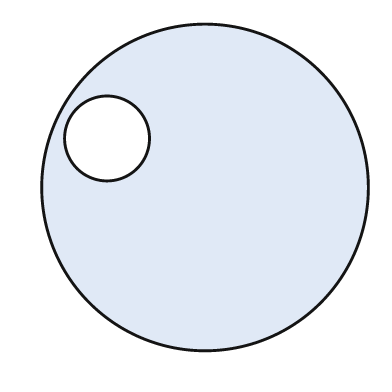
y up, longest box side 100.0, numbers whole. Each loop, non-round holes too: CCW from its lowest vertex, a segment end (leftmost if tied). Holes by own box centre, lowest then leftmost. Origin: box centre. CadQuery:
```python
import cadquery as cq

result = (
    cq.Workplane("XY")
    .moveTo(0.0, 0.0)
    .circle(50.0)
    .moveTo(-30.0, 15.0)
    .circle(13.0)
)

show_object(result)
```